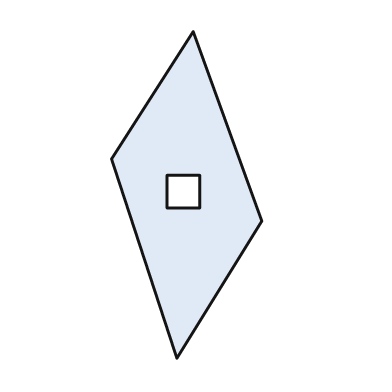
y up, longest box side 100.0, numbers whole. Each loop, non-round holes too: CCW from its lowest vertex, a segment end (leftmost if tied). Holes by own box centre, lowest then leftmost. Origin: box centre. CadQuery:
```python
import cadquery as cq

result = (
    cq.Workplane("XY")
    .moveTo(-3.0, -50.0)
    .lineTo(23.0, -8.0)
    .lineTo(2.0, 50.0)
    .lineTo(-23.0, 11.0)
    .close()
    .moveTo(-6.0, -4.0)
    .lineTo(4.0, -4.0)
    .lineTo(4.0, 6.0)
    .lineTo(-6.0, 6.0)
    .close()
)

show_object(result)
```